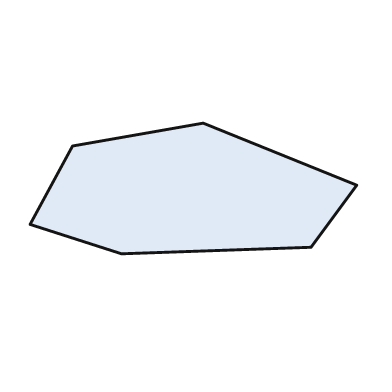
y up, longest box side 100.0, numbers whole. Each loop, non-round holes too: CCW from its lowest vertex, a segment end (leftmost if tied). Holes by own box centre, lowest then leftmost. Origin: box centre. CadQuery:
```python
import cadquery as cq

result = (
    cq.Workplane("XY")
    .moveTo(-22.0, -20.0)
    .lineTo(36.0, -18.0)
    .lineTo(50.0, 1.0)
    .lineTo(3.0, 20.0)
    .lineTo(-37.0, 13.0)
    .lineTo(-50.0, -11.0)
    .close()
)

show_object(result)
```